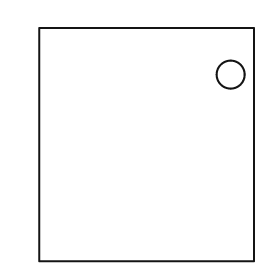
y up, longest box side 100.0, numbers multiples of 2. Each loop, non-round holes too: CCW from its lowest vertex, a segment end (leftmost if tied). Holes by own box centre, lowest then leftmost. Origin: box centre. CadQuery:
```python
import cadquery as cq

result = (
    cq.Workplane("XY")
    .moveTo(-46.0, -50.0)
    .lineTo(46.0, -50.0)
    .lineTo(46.0, 50.0)
    .lineTo(-46.0, 50.0)
    .close()
    .moveTo(36.0, 30.0)
    .circle(6.0)
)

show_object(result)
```